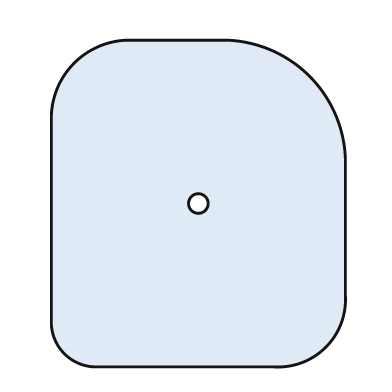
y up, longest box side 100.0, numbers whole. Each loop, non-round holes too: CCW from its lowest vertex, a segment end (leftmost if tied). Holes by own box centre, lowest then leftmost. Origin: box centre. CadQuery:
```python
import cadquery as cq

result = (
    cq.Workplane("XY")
    .moveTo(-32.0, -50.0)
    .lineTo(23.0, -50.0)
    .threePointArc((39.0, -44.0), (45.0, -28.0))
    .lineTo(45.0, 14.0)
    .threePointArc((34.0, 39.0), (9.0, 50.0))
    .lineTo(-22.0, 50.0)
    .threePointArc((-38.0, 43.0), (-45.0, 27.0))
    .lineTo(-45.0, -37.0)
    .threePointArc((-41.0, -46.0), (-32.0, -50.0))
    .close()
    .moveTo(0.0, 0.0)
    .circle(3.0)
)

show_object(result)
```